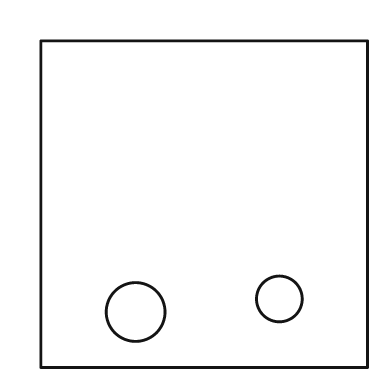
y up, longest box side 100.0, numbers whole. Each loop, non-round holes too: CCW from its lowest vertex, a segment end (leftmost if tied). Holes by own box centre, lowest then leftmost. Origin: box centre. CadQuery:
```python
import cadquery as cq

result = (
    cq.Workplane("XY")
    .moveTo(-50.0, -50.0)
    .lineTo(50.0, -50.0)
    .lineTo(50.0, 50.0)
    .lineTo(-50.0, 50.0)
    .close()
    .moveTo(-21.0, -33.0)
    .circle(9.0)
    .moveTo(23.0, -29.0)
    .circle(7.0)
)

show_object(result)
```